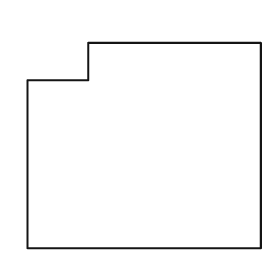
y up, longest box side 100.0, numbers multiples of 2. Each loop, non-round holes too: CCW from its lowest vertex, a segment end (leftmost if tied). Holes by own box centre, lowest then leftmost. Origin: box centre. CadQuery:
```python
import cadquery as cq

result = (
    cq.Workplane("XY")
    .moveTo(-50.0, -44.0)
    .lineTo(50.0, -44.0)
    .lineTo(50.0, 44.0)
    .lineTo(-24.0, 44.0)
    .lineTo(-24.0, 28.0)
    .lineTo(-50.0, 28.0)
    .close()
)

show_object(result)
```